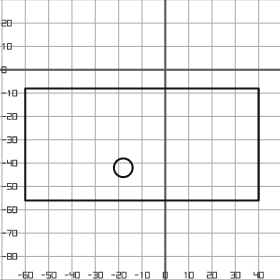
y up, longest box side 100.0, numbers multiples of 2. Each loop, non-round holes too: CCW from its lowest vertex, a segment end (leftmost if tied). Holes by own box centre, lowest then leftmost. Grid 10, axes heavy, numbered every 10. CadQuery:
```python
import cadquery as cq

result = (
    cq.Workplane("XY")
    .moveTo(-60.0, -56.0)
    .lineTo(40.0, -56.0)
    .lineTo(40.0, -8.0)
    .lineTo(-60.0, -8.0)
    .close()
    .moveTo(-18.0, -42.0)
    .circle(4.0)
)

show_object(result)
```